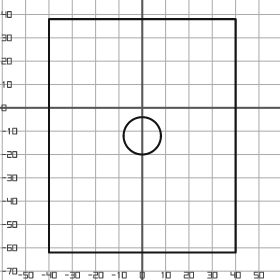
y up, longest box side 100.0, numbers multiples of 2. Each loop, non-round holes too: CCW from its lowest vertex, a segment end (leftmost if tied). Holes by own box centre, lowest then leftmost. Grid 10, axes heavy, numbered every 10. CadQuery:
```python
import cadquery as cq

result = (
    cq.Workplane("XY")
    .moveTo(-40.0, -62.0)
    .lineTo(40.0, -62.0)
    .lineTo(40.0, 38.0)
    .lineTo(-40.0, 38.0)
    .close()
    .moveTo(0.0, -12.0)
    .circle(8.0)
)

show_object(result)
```